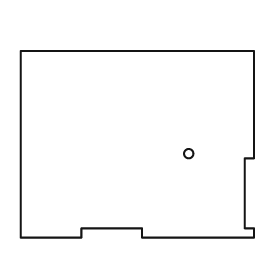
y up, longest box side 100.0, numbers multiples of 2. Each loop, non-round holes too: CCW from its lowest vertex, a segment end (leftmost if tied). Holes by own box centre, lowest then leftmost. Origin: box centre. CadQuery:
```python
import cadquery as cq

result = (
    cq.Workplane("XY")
    .moveTo(-50.0, -40.0)
    .lineTo(-24.0, -40.0)
    .lineTo(-24.0, -36.0)
    .lineTo(2.0, -36.0)
    .lineTo(2.0, -40.0)
    .lineTo(50.0, -40.0)
    .lineTo(50.0, -36.0)
    .lineTo(46.0, -36.0)
    .lineTo(46.0, -6.0)
    .lineTo(50.0, -6.0)
    .lineTo(50.0, 40.0)
    .lineTo(-50.0, 40.0)
    .close()
    .moveTo(22.0, -4.0)
    .circle(2.0)
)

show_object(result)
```